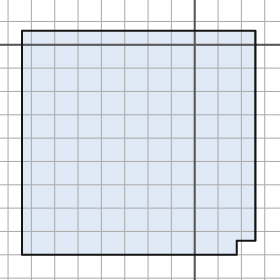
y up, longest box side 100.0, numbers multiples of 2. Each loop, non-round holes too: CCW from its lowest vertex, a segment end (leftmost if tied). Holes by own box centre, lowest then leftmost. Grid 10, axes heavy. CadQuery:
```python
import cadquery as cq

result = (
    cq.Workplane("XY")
    .moveTo(-74.0, -90.0)
    .lineTo(18.0, -90.0)
    .lineTo(18.0, -84.0)
    .lineTo(26.0, -84.0)
    .lineTo(26.0, 6.0)
    .lineTo(-74.0, 6.0)
    .close()
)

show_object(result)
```